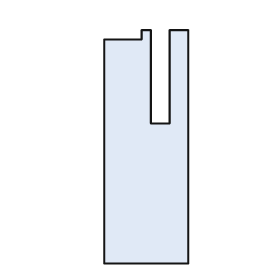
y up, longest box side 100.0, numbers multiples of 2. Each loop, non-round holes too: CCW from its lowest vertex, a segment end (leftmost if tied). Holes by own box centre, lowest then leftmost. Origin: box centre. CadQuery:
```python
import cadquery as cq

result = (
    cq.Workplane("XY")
    .moveTo(-18.0, -50.0)
    .lineTo(18.0, -50.0)
    .lineTo(18.0, 50.0)
    .lineTo(10.0, 50.0)
    .lineTo(10.0, 10.0)
    .lineTo(2.0, 10.0)
    .lineTo(2.0, 50.0)
    .lineTo(-2.0, 50.0)
    .lineTo(-2.0, 46.0)
    .lineTo(-18.0, 46.0)
    .close()
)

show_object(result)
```